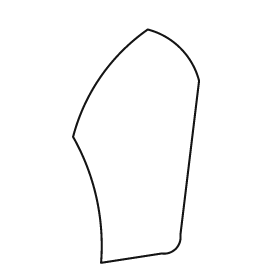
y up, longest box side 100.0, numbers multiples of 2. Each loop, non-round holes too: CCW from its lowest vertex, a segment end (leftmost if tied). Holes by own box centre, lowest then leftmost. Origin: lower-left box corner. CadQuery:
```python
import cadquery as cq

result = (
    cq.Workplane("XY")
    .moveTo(12.0, 0.0)
    .lineTo(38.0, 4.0)
    .threePointArc((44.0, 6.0), (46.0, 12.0))
    .lineTo(54.0, 78.0)
    .threePointArc((46.0, 92.0), (32.0, 100.0))
    .threePointArc((12.0, 80.0), (0.0, 54.0))
    .threePointArc((10.0, 28.0), (12.0, 0.0))
    .close()
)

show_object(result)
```